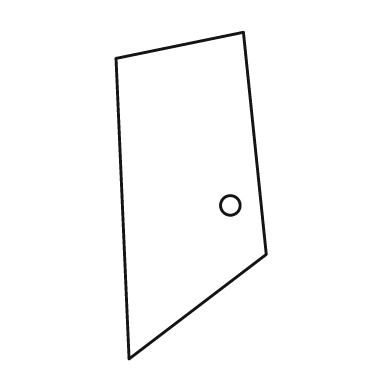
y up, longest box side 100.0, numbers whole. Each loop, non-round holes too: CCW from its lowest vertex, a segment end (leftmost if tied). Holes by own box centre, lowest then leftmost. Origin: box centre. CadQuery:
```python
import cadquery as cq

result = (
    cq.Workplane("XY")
    .moveTo(-19.0, -50.0)
    .lineTo(23.0, -18.0)
    .lineTo(16.0, 50.0)
    .lineTo(-23.0, 42.0)
    .close()
    .moveTo(12.0, -3.0)
    .circle(3.0)
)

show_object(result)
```